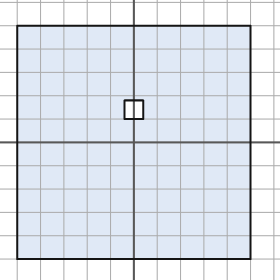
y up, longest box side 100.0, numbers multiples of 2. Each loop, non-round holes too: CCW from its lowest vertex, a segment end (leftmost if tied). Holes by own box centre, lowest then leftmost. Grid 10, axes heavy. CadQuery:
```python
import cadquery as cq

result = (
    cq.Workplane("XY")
    .moveTo(-50.0, -50.0)
    .lineTo(50.0, -50.0)
    .lineTo(50.0, 50.0)
    .lineTo(-50.0, 50.0)
    .close()
    .moveTo(-4.0, 10.0)
    .lineTo(4.0, 10.0)
    .lineTo(4.0, 18.0)
    .lineTo(-4.0, 18.0)
    .close()
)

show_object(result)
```